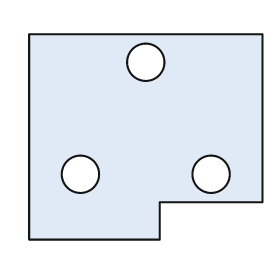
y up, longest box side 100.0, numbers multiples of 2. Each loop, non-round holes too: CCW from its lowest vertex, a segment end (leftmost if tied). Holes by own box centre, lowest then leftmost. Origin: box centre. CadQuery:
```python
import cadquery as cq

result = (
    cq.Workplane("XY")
    .moveTo(-50.0, -44.0)
    .lineTo(6.0, -44.0)
    .lineTo(6.0, -28.0)
    .lineTo(50.0, -28.0)
    .lineTo(50.0, 44.0)
    .lineTo(-50.0, 44.0)
    .close()
    .moveTo(-28.0, -16.0)
    .circle(8.0)
    .moveTo(28.0, -16.0)
    .circle(8.0)
    .moveTo(0.0, 32.0)
    .circle(8.0)
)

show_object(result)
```